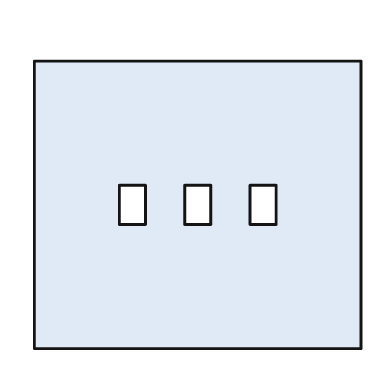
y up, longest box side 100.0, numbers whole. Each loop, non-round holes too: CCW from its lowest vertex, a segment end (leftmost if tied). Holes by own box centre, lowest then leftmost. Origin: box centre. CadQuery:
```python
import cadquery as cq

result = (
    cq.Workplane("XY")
    .moveTo(-50.0, -44.0)
    .lineTo(50.0, -44.0)
    .lineTo(50.0, 44.0)
    .lineTo(-50.0, 44.0)
    .close()
    .moveTo(-24.0, -6.0)
    .lineTo(-16.0, -6.0)
    .lineTo(-16.0, 6.0)
    .lineTo(-24.0, 6.0)
    .close()
    .moveTo(-4.0, -6.0)
    .lineTo(4.0, -6.0)
    .lineTo(4.0, 6.0)
    .lineTo(-4.0, 6.0)
    .close()
    .moveTo(16.0, -6.0)
    .lineTo(24.0, -6.0)
    .lineTo(24.0, 6.0)
    .lineTo(16.0, 6.0)
    .close()
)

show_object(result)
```